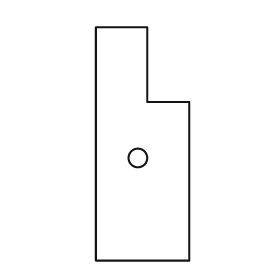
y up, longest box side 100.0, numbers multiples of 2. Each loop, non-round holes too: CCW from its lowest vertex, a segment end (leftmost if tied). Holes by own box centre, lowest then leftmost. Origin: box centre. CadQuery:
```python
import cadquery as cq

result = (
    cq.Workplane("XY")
    .moveTo(-20.0, -50.0)
    .lineTo(20.0, -50.0)
    .lineTo(20.0, 18.0)
    .lineTo(2.0, 18.0)
    .lineTo(2.0, 50.0)
    .lineTo(-20.0, 50.0)
    .close()
    .moveTo(-2.0, -6.0)
    .circle(4.0)
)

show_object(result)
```